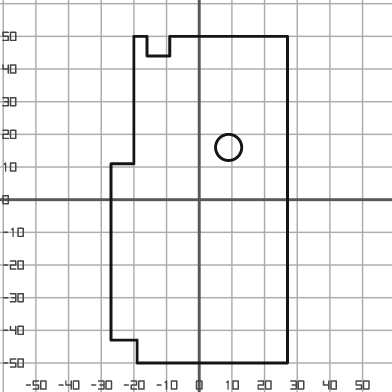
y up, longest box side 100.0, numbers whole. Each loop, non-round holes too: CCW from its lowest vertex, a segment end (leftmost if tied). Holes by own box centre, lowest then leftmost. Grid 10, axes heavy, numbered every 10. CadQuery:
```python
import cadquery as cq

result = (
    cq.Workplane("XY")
    .moveTo(-19.0, -50.0)
    .lineTo(27.0, -50.0)
    .lineTo(27.0, 50.0)
    .lineTo(-9.0, 50.0)
    .lineTo(-9.0, 44.0)
    .lineTo(-16.0, 44.0)
    .lineTo(-16.0, 50.0)
    .lineTo(-20.0, 50.0)
    .lineTo(-20.0, 11.0)
    .lineTo(-27.0, 11.0)
    .lineTo(-27.0, -43.0)
    .lineTo(-19.0, -43.0)
    .close()
    .moveTo(9.0, 16.0)
    .circle(4.0)
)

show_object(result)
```